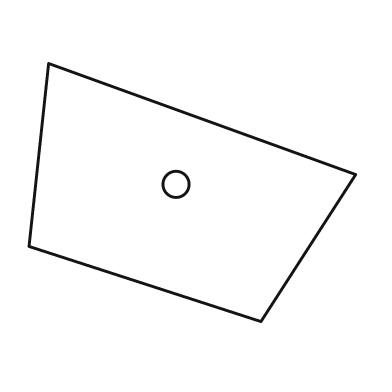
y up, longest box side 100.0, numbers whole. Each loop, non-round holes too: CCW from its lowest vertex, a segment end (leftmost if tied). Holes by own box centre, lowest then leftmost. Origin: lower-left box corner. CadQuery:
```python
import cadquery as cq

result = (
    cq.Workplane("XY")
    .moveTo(71.0, 0.0)
    .lineTo(100.0, 45.0)
    .lineTo(6.0, 79.0)
    .lineTo(0.0, 23.0)
    .close()
    .moveTo(45.0, 42.0)
    .circle(4.0)
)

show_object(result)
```